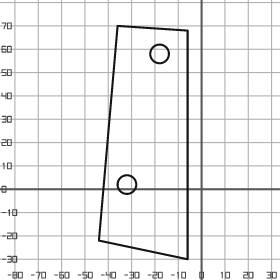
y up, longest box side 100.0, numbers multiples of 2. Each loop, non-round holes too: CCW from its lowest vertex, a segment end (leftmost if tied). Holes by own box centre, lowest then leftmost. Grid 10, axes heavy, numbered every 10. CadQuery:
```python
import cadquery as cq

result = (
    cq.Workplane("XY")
    .moveTo(-6.0, -30.0)
    .lineTo(-6.0, 68.0)
    .lineTo(-36.0, 70.0)
    .lineTo(-44.0, -22.0)
    .close()
    .moveTo(-32.0, 2.0)
    .circle(4.0)
    .moveTo(-18.0, 58.0)
    .circle(4.0)
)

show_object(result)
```